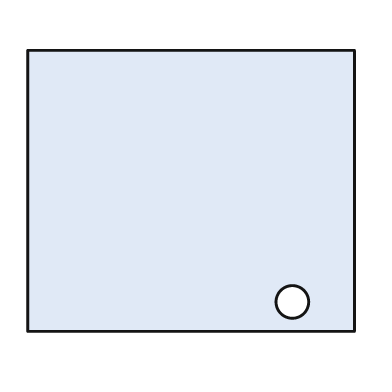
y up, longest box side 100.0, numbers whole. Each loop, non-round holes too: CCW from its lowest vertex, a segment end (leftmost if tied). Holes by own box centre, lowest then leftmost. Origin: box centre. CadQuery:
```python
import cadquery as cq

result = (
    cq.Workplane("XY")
    .moveTo(-50.0, -43.0)
    .lineTo(50.0, -43.0)
    .lineTo(50.0, 43.0)
    .lineTo(-50.0, 43.0)
    .close()
    .moveTo(31.0, -34.0)
    .circle(5.0)
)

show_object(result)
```